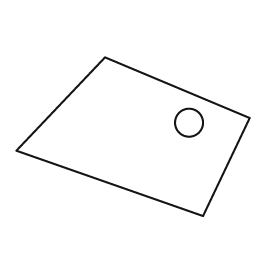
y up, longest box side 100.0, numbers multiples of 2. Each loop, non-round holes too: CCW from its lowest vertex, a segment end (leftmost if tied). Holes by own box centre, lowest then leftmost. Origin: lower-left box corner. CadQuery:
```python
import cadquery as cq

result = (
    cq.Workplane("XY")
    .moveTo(80.0, 0.0)
    .lineTo(100.0, 42.0)
    .lineTo(38.0, 68.0)
    .lineTo(0.0, 28.0)
    .close()
    .moveTo(74.0, 40.0)
    .circle(6.0)
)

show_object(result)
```